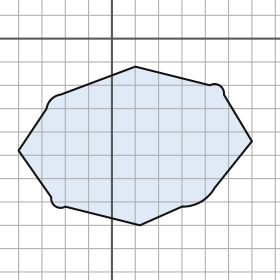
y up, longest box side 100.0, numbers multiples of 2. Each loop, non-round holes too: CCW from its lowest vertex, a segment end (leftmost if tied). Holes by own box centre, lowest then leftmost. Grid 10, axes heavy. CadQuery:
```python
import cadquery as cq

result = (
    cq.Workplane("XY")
    .moveTo(12.0, -80.0)
    .lineTo(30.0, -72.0)
    .threePointArc((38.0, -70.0), (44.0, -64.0))
    .lineTo(60.0, -44.0)
    .lineTo(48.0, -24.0)
    .threePointArc((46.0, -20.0), (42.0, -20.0))
    .lineTo(10.0, -12.0)
    .lineTo(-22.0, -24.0)
    .threePointArc((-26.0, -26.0), (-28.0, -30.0))
    .lineTo(-40.0, -48.0)
    .lineTo(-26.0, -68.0)
    .threePointArc((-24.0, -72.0), (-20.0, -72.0))
    .close()
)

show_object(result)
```